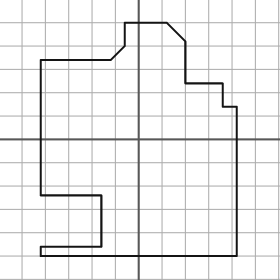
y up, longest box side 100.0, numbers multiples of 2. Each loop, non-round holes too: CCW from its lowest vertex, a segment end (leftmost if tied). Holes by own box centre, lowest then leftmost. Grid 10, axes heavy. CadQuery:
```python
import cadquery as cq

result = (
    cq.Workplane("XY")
    .moveTo(-42.0, -50.0)
    .lineTo(42.0, -50.0)
    .lineTo(42.0, 14.0)
    .lineTo(36.0, 14.0)
    .lineTo(36.0, 24.0)
    .lineTo(20.0, 24.0)
    .lineTo(20.0, 42.0)
    .lineTo(12.0, 50.0)
    .lineTo(-6.0, 50.0)
    .lineTo(-6.0, 40.0)
    .lineTo(-12.0, 34.0)
    .lineTo(-42.0, 34.0)
    .lineTo(-42.0, -24.0)
    .lineTo(-16.0, -24.0)
    .lineTo(-16.0, -46.0)
    .lineTo(-42.0, -46.0)
    .close()
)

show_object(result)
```